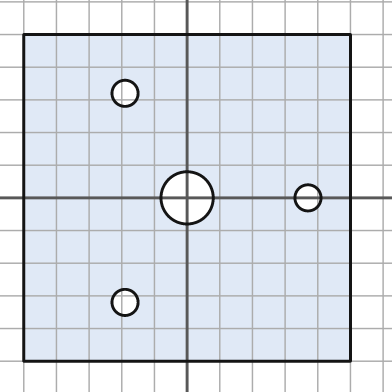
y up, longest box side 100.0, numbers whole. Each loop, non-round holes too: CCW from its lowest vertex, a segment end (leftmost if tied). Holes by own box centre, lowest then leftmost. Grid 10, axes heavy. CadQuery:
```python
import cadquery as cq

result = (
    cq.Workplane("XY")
    .moveTo(-50.0, -50.0)
    .lineTo(50.0, -50.0)
    .lineTo(50.0, 50.0)
    .lineTo(-50.0, 50.0)
    .close()
    .moveTo(-19.0, -32.0)
    .circle(4.0)
    .moveTo(0.0, 0.0)
    .circle(8.0)
    .moveTo(37.0, 0.0)
    .circle(4.0)
    .moveTo(-19.0, 32.0)
    .circle(4.0)
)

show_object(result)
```